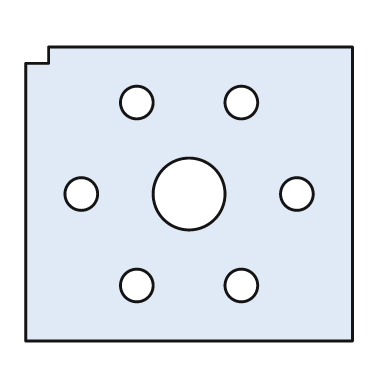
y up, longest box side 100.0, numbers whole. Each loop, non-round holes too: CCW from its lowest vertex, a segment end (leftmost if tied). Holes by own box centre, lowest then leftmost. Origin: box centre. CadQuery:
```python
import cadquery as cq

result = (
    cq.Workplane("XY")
    .moveTo(-50.0, -45.0)
    .lineTo(50.0, -45.0)
    .lineTo(50.0, 45.0)
    .lineTo(-43.0, 45.0)
    .lineTo(-43.0, 40.0)
    .lineTo(-50.0, 40.0)
    .close()
    .moveTo(-16.0, -28.0)
    .circle(5.0)
    .moveTo(16.0, -28.0)
    .circle(5.0)
    .moveTo(-33.0, 0.0)
    .circle(5.0)
    .moveTo(0.0, 0.0)
    .circle(11.0)
    .moveTo(33.0, 0.0)
    .circle(5.0)
    .moveTo(-16.0, 28.0)
    .circle(5.0)
    .moveTo(16.0, 28.0)
    .circle(5.0)
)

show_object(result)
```